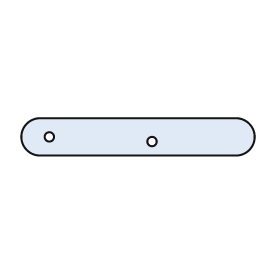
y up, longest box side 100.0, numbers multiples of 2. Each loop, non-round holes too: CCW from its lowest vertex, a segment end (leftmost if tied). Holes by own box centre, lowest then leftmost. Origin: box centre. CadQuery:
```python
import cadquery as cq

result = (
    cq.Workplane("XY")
    .moveTo(-42.0, -8.0)
    .lineTo(42.0, -8.0)
    .threePointArc((50.0, 0.0), (42.0, 8.0))
    .lineTo(-42.0, 8.0)
    .threePointArc((-50.0, 0.0), (-42.0, -8.0))
    .close()
    .moveTo(6.0, -2.0)
    .circle(2.0)
    .moveTo(-38.0, 0.0)
    .circle(2.0)
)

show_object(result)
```